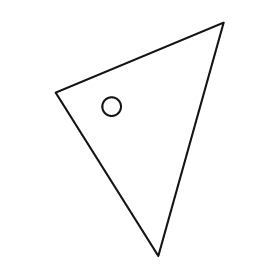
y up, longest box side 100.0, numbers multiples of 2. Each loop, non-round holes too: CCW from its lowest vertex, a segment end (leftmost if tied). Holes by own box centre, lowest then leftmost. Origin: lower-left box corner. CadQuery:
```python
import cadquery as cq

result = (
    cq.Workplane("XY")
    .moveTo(44.0, 0.0)
    .lineTo(72.0, 100.0)
    .lineTo(0.0, 70.0)
    .close()
    .moveTo(24.0, 64.0)
    .circle(4.0)
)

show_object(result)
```